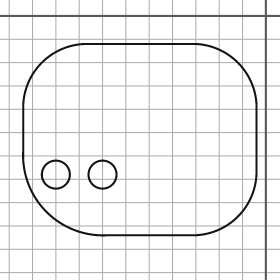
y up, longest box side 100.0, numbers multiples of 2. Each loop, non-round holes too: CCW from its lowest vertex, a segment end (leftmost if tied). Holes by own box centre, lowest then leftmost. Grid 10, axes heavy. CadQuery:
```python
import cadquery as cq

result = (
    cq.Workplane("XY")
    .moveTo(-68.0, -94.0)
    .lineTo(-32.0, -94.0)
    .threePointArc((-12.0, -86.0), (-4.0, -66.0))
    .lineTo(-4.0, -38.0)
    .threePointArc((-12.0, -20.0), (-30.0, -12.0))
    .lineTo(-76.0, -12.0)
    .threePointArc((-96.0, -20.0), (-104.0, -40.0))
    .lineTo(-104.0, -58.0)
    .threePointArc((-94.0, -84.0), (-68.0, -94.0))
    .close()
    .moveTo(-90.0, -68.0)
    .circle(6.0)
    .moveTo(-70.0, -68.0)
    .circle(6.0)
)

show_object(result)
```